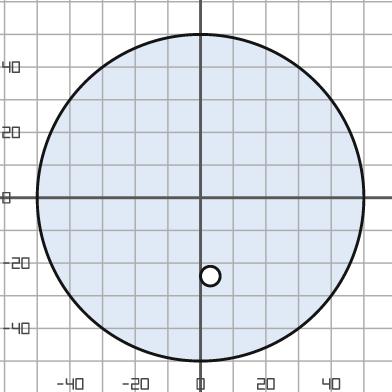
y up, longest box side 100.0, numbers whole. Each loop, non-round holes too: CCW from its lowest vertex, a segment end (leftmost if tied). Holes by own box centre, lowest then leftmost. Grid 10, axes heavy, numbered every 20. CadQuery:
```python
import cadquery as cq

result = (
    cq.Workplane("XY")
    .moveTo(0.0, 0.0)
    .circle(50.0)
    .moveTo(3.0, -24.0)
    .circle(3.0)
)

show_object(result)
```